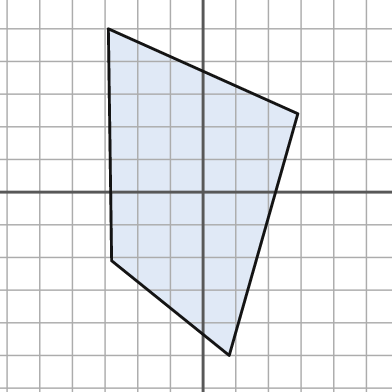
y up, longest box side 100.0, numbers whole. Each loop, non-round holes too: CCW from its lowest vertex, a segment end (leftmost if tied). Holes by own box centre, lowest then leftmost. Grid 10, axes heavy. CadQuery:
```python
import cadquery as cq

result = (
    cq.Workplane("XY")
    .moveTo(8.0, -50.0)
    .lineTo(29.0, 24.0)
    .lineTo(-29.0, 50.0)
    .lineTo(-28.0, -21.0)
    .close()
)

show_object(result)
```